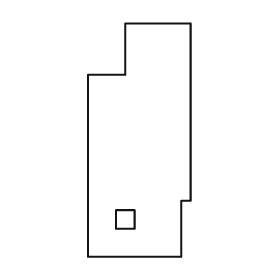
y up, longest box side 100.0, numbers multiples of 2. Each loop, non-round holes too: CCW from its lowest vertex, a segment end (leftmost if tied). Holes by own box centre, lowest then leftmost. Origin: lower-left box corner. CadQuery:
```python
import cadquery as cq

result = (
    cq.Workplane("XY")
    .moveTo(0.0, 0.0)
    .lineTo(40.0, 0.0)
    .lineTo(40.0, 24.0)
    .lineTo(44.0, 24.0)
    .lineTo(44.0, 100.0)
    .lineTo(16.0, 100.0)
    .lineTo(16.0, 78.0)
    .lineTo(0.0, 78.0)
    .close()
    .moveTo(12.0, 12.0)
    .lineTo(20.0, 12.0)
    .lineTo(20.0, 20.0)
    .lineTo(12.0, 20.0)
    .close()
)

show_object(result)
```